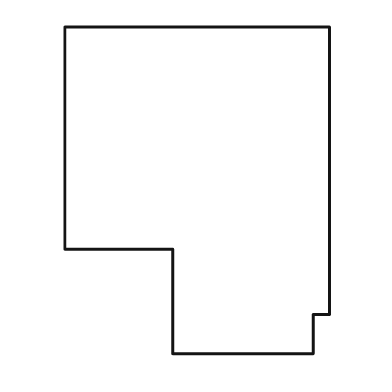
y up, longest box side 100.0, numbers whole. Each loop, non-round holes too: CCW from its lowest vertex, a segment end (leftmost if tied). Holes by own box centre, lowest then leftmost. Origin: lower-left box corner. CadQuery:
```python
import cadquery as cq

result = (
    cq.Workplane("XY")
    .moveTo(33.0, 0.0)
    .lineTo(76.0, 0.0)
    .lineTo(76.0, 12.0)
    .lineTo(81.0, 12.0)
    .lineTo(81.0, 100.0)
    .lineTo(0.0, 100.0)
    .lineTo(0.0, 32.0)
    .lineTo(33.0, 32.0)
    .close()
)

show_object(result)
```